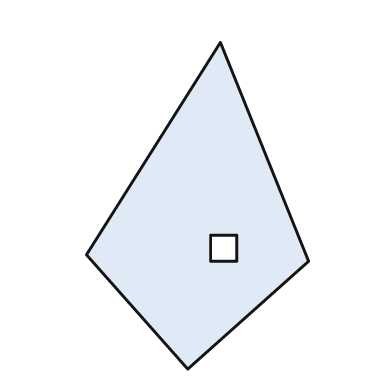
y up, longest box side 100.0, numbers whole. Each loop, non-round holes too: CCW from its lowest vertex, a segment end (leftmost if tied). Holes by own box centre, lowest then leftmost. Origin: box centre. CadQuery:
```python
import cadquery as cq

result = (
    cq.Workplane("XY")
    .moveTo(-3.0, -50.0)
    .lineTo(34.0, -17.0)
    .lineTo(7.0, 50.0)
    .lineTo(-34.0, -15.0)
    .close()
    .moveTo(4.0, -17.0)
    .lineTo(12.0, -17.0)
    .lineTo(12.0, -9.0)
    .lineTo(4.0, -9.0)
    .close()
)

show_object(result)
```